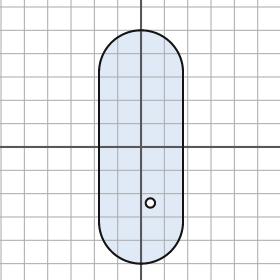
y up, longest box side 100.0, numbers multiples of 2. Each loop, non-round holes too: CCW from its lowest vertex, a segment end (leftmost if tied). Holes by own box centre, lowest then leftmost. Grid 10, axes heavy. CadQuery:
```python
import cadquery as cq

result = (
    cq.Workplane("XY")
    .moveTo(-18.0, -32.0)
    .threePointArc((0.0, -50.0), (18.0, -32.0))
    .lineTo(18.0, 32.0)
    .threePointArc((0.0, 50.0), (-18.0, 32.0))
    .close()
    .moveTo(4.0, -24.0)
    .circle(2.0)
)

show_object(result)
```